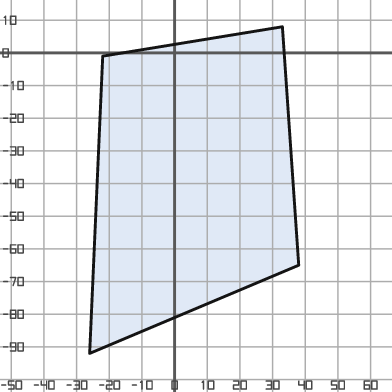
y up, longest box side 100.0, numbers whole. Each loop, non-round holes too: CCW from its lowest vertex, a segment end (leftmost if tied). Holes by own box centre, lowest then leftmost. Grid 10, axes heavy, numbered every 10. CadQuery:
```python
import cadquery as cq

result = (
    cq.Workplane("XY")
    .moveTo(-26.0, -92.0)
    .lineTo(38.0, -65.0)
    .lineTo(33.0, 8.0)
    .lineTo(-22.0, -1.0)
    .close()
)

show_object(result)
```